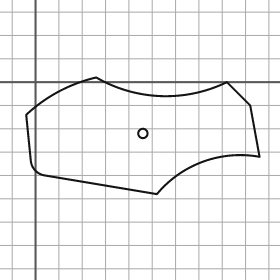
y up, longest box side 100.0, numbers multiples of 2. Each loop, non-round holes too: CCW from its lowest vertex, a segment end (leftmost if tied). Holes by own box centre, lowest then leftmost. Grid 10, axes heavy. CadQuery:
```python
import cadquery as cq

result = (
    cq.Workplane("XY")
    .moveTo(52.0, -48.0)
    .threePointArc((72.0, -34.0), (96.0, -32.0))
    .lineTo(92.0, -10.0)
    .lineTo(82.0, 0.0)
    .threePointArc((54.0, -6.0), (26.0, 2.0))
    .threePointArc((10.0, -4.0), (-4.0, -14.0))
    .lineTo(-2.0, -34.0)
    .threePointArc((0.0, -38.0), (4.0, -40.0))
    .close()
    .moveTo(46.0, -22.0)
    .circle(2.0)
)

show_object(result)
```